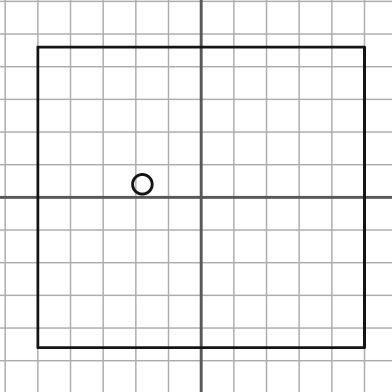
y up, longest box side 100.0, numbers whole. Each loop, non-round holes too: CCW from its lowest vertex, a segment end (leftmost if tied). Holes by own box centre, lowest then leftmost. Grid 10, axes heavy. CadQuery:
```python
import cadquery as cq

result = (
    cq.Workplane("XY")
    .moveTo(-50.0, -46.0)
    .lineTo(50.0, -46.0)
    .lineTo(50.0, 46.0)
    .lineTo(-50.0, 46.0)
    .close()
    .moveTo(-18.0, 4.0)
    .circle(3.0)
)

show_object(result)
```